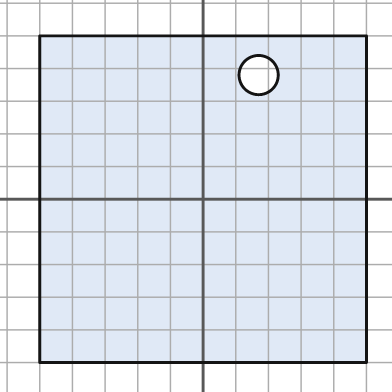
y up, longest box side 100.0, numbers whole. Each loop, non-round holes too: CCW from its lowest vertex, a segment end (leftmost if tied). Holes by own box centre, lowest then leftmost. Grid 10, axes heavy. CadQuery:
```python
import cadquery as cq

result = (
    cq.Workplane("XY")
    .moveTo(-50.0, -50.0)
    .lineTo(50.0, -50.0)
    .lineTo(50.0, 50.0)
    .lineTo(-50.0, 50.0)
    .close()
    .moveTo(17.0, 38.0)
    .circle(6.0)
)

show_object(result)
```